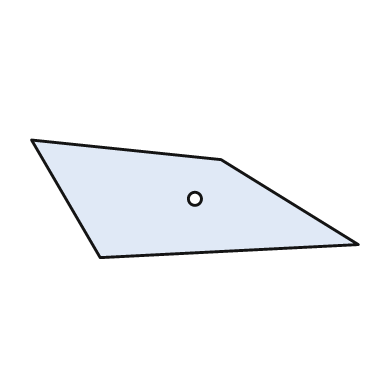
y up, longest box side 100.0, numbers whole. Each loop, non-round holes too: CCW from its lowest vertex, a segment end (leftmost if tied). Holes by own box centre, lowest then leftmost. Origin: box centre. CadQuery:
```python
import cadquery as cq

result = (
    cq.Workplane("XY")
    .moveTo(-29.0, -18.0)
    .lineTo(50.0, -14.0)
    .lineTo(8.0, 12.0)
    .lineTo(-50.0, 18.0)
    .close()
    .moveTo(0.0, 0.0)
    .circle(2.0)
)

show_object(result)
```